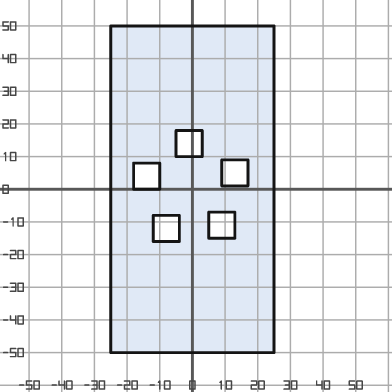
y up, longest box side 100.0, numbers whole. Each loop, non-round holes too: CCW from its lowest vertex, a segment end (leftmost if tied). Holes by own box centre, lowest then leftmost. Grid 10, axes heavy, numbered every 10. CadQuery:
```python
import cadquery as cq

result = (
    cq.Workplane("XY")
    .moveTo(-25.0, -50.0)
    .lineTo(25.0, -50.0)
    .lineTo(25.0, 50.0)
    .lineTo(-25.0, 50.0)
    .close()
    .moveTo(-12.0, -16.0)
    .lineTo(-4.0, -16.0)
    .lineTo(-4.0, -8.0)
    .lineTo(-12.0, -8.0)
    .close()
    .moveTo(5.0, -15.0)
    .lineTo(13.0, -15.0)
    .lineTo(13.0, -7.0)
    .lineTo(5.0, -7.0)
    .close()
    .moveTo(-18.0, 0.0)
    .lineTo(-10.0, 0.0)
    .lineTo(-10.0, 8.0)
    .lineTo(-18.0, 8.0)
    .close()
    .moveTo(9.0, 1.0)
    .lineTo(17.0, 1.0)
    .lineTo(17.0, 9.0)
    .lineTo(9.0, 9.0)
    .close()
    .moveTo(-5.0, 10.0)
    .lineTo(3.0, 10.0)
    .lineTo(3.0, 18.0)
    .lineTo(-5.0, 18.0)
    .close()
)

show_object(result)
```